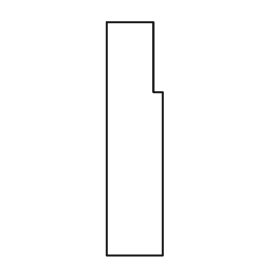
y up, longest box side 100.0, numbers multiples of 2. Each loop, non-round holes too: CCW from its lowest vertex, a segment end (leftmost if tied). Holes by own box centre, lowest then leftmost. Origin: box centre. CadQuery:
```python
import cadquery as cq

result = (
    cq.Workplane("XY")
    .moveTo(-12.0, -50.0)
    .lineTo(12.0, -50.0)
    .lineTo(12.0, 20.0)
    .lineTo(8.0, 20.0)
    .lineTo(8.0, 50.0)
    .lineTo(-12.0, 50.0)
    .close()
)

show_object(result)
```